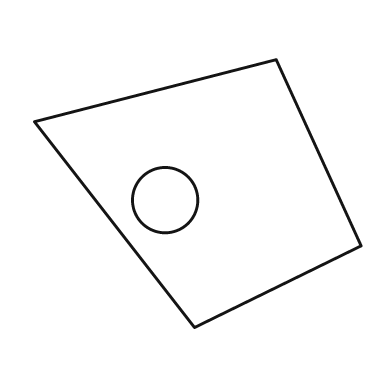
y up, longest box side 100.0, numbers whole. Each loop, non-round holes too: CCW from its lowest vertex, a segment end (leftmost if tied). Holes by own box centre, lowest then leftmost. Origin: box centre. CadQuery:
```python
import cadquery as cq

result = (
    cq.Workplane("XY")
    .moveTo(-1.0, -41.0)
    .lineTo(50.0, -16.0)
    .lineTo(24.0, 41.0)
    .lineTo(-50.0, 22.0)
    .close()
    .moveTo(-10.0, -2.0)
    .circle(10.0)
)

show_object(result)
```